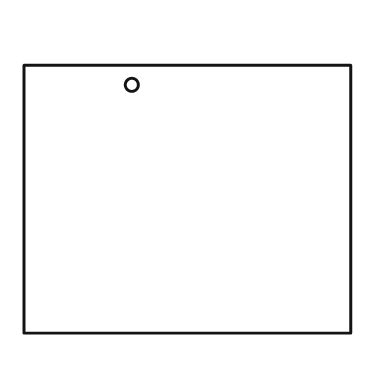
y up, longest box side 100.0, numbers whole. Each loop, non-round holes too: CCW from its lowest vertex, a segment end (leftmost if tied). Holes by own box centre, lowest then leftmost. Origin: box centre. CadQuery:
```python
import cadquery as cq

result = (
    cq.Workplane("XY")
    .moveTo(-50.0, -41.0)
    .lineTo(50.0, -41.0)
    .lineTo(50.0, 41.0)
    .lineTo(-50.0, 41.0)
    .close()
    .moveTo(-17.0, 35.0)
    .circle(2.0)
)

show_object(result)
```